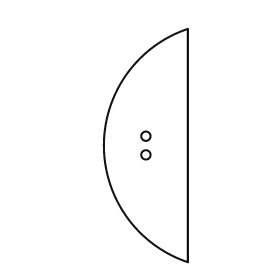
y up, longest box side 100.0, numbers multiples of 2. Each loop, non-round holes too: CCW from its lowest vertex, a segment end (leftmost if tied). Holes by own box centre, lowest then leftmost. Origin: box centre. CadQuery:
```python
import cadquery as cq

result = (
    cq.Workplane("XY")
    .moveTo(18.0, -50.0)
    .lineTo(18.0, 50.0)
    .threePointArc((-18.0, 0.0), (18.0, -50.0))
    .close()
    .moveTo(0.0, -4.0)
    .circle(2.0)
    .moveTo(0.0, 4.0)
    .circle(2.0)
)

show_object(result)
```